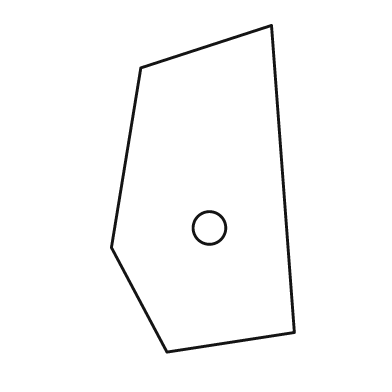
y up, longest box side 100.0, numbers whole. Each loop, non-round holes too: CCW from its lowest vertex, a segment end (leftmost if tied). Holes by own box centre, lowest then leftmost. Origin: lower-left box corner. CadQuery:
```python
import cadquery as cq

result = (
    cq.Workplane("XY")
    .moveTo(17.0, 0.0)
    .lineTo(56.0, 6.0)
    .lineTo(49.0, 100.0)
    .lineTo(9.0, 87.0)
    .lineTo(0.0, 32.0)
    .close()
    .moveTo(30.0, 38.0)
    .circle(5.0)
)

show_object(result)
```